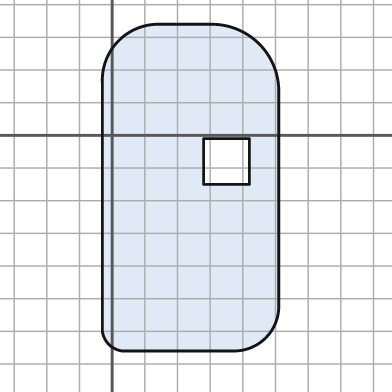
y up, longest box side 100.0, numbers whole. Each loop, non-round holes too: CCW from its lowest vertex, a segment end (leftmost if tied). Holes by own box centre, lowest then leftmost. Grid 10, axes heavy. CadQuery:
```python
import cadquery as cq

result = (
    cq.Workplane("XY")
    .moveTo(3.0, -66.0)
    .lineTo(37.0, -66.0)
    .threePointArc((47.0, -62.0), (51.0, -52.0))
    .lineTo(51.0, 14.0)
    .threePointArc((45.0, 28.0), (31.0, 34.0))
    .lineTo(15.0, 34.0)
    .threePointArc((2.0, 29.0), (-3.0, 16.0))
    .lineTo(-3.0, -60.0)
    .threePointArc((-1.0, -64.0), (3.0, -66.0))
    .close()
    .moveTo(28.0, -15.0)
    .lineTo(42.0, -15.0)
    .lineTo(42.0, -1.0)
    .lineTo(28.0, -1.0)
    .close()
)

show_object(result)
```